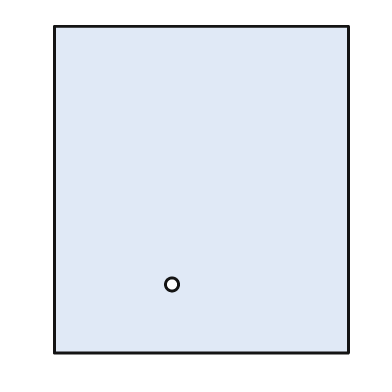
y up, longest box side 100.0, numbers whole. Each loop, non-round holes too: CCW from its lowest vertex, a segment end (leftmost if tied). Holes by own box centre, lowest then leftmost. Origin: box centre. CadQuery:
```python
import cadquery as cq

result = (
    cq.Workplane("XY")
    .moveTo(-45.0, -50.0)
    .lineTo(45.0, -50.0)
    .lineTo(45.0, 50.0)
    .lineTo(-45.0, 50.0)
    .close()
    .moveTo(-9.0, -29.0)
    .circle(2.0)
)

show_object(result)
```